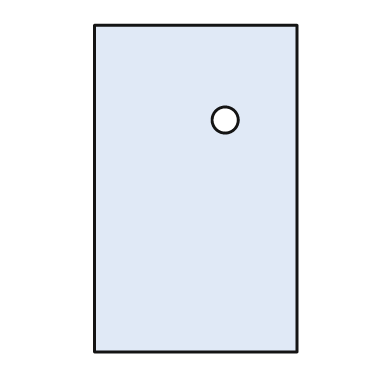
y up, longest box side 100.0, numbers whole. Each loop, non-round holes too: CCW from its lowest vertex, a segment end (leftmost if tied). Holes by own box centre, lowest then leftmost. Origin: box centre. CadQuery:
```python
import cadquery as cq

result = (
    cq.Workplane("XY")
    .moveTo(-31.0, -50.0)
    .lineTo(31.0, -50.0)
    .lineTo(31.0, 50.0)
    .lineTo(-31.0, 50.0)
    .close()
    .moveTo(9.0, 21.0)
    .circle(4.0)
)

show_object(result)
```